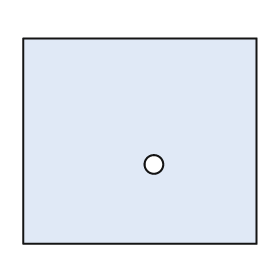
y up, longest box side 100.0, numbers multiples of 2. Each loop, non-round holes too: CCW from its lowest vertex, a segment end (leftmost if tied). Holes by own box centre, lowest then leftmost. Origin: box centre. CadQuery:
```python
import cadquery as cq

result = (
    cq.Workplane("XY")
    .moveTo(-50.0, -44.0)
    .lineTo(50.0, -44.0)
    .lineTo(50.0, 44.0)
    .lineTo(-50.0, 44.0)
    .close()
    .moveTo(6.0, -10.0)
    .circle(4.0)
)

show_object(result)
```